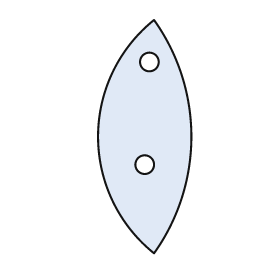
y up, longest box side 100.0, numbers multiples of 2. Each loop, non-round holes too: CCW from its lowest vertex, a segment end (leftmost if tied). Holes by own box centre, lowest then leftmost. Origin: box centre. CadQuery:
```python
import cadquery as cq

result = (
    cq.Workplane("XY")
    .moveTo(4.0, -50.0)
    .threePointArc((20.0, 0.0), (4.0, 50.0))
    .threePointArc((-20.0, 0.0), (4.0, -50.0))
    .close()
    .moveTo(0.0, -12.0)
    .circle(4.0)
    .moveTo(2.0, 32.0)
    .circle(4.0)
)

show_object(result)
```